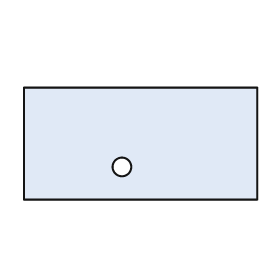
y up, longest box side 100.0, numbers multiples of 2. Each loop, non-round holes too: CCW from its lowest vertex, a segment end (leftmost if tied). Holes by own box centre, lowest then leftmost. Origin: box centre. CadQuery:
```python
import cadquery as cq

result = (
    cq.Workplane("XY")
    .moveTo(-50.0, -24.0)
    .lineTo(50.0, -24.0)
    .lineTo(50.0, 24.0)
    .lineTo(-50.0, 24.0)
    .close()
    .moveTo(-8.0, -10.0)
    .circle(4.0)
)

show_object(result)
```